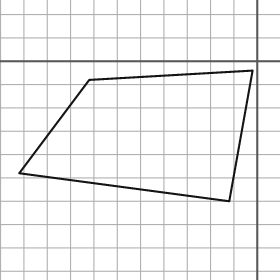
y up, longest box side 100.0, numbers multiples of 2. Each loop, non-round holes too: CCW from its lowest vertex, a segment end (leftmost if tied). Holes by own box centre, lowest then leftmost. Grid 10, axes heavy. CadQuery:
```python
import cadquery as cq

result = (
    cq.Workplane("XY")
    .moveTo(-12.0, -60.0)
    .lineTo(-2.0, -4.0)
    .lineTo(-72.0, -8.0)
    .lineTo(-102.0, -48.0)
    .close()
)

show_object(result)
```